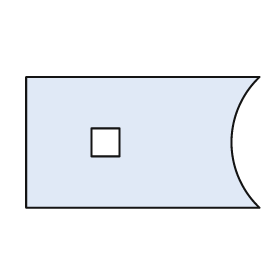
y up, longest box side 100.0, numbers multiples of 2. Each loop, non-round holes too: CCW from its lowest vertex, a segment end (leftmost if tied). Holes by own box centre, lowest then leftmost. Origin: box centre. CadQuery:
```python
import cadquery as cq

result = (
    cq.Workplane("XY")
    .moveTo(-50.0, -28.0)
    .lineTo(50.0, -28.0)
    .threePointArc((38.0, 0.0), (50.0, 28.0))
    .lineTo(-50.0, 28.0)
    .close()
    .moveTo(-22.0, -6.0)
    .lineTo(-10.0, -6.0)
    .lineTo(-10.0, 6.0)
    .lineTo(-22.0, 6.0)
    .close()
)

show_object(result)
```